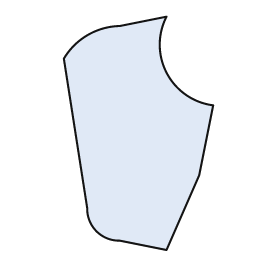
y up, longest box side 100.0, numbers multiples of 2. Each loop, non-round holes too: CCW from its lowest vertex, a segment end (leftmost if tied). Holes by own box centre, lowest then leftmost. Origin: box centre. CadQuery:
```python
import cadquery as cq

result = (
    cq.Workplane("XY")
    .moveTo(12.0, -50.0)
    .lineTo(26.0, -18.0)
    .lineTo(32.0, 12.0)
    .threePointArc((12.0, 26.0), (12.0, 50.0))
    .lineTo(-8.0, 46.0)
    .threePointArc((-22.0, 42.0), (-32.0, 32.0))
    .lineTo(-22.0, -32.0)
    .threePointArc((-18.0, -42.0), (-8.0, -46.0))
    .close()
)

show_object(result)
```